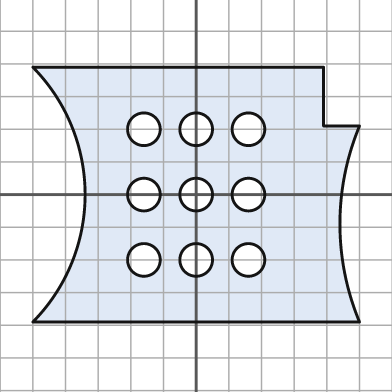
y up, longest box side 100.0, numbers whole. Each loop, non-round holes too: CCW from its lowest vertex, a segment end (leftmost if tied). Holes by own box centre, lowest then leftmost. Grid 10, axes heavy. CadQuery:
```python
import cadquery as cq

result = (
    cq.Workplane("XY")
    .moveTo(-50.0, -39.0)
    .lineTo(50.0, -39.0)
    .threePointArc((44.0, -9.0), (50.0, 21.0))
    .lineTo(39.0, 21.0)
    .lineTo(39.0, 39.0)
    .lineTo(-50.0, 39.0)
    .threePointArc((-34.0, 0.0), (-50.0, -39.0))
    .close()
    .moveTo(-16.0, -20.0)
    .circle(5.0)
    .moveTo(0.0, -20.0)
    .circle(5.0)
    .moveTo(16.0, -20.0)
    .circle(5.0)
    .moveTo(-16.0, 0.0)
    .circle(5.0)
    .moveTo(0.0, 0.0)
    .circle(5.0)
    .moveTo(16.0, 0.0)
    .circle(5.0)
    .moveTo(-16.0, 20.0)
    .circle(5.0)
    .moveTo(0.0, 20.0)
    .circle(5.0)
    .moveTo(16.0, 20.0)
    .circle(5.0)
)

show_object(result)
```